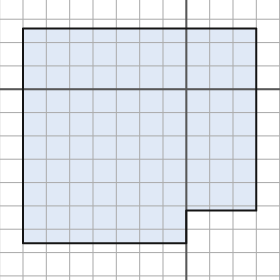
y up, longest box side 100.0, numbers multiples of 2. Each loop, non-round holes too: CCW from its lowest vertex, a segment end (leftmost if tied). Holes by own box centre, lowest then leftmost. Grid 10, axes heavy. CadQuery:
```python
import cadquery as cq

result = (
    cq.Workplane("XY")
    .moveTo(-70.0, -66.0)
    .lineTo(0.0, -66.0)
    .lineTo(0.0, -52.0)
    .lineTo(30.0, -52.0)
    .lineTo(30.0, 26.0)
    .lineTo(-70.0, 26.0)
    .close()
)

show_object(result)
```